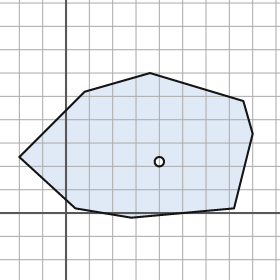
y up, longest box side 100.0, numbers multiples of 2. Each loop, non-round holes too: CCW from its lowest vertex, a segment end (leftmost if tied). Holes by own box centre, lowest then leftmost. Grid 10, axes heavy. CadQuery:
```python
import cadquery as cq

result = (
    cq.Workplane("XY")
    .moveTo(28.0, -2.0)
    .lineTo(72.0, 2.0)
    .lineTo(80.0, 34.0)
    .lineTo(76.0, 48.0)
    .lineTo(36.0, 60.0)
    .lineTo(8.0, 52.0)
    .lineTo(-20.0, 24.0)
    .lineTo(4.0, 2.0)
    .close()
    .moveTo(40.0, 22.0)
    .circle(2.0)
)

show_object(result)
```